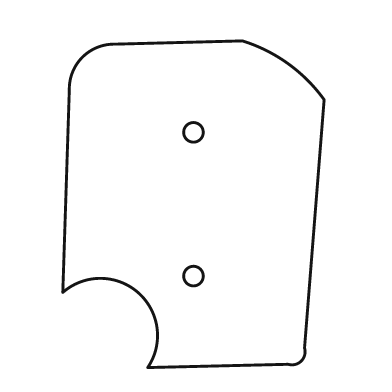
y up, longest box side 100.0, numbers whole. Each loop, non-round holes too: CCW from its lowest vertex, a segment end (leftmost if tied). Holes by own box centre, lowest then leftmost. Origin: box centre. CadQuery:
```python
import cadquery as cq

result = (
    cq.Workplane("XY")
    .moveTo(-14.0, -50.0)
    .lineTo(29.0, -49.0)
    .threePointArc((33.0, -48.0), (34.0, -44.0))
    .lineTo(40.0, 32.0)
    .threePointArc((29.0, 43.0), (15.0, 50.0))
    .lineTo(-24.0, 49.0)
    .threePointArc((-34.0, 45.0), (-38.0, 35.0))
    .lineTo(-40.0, -27.0)
    .threePointArc((-17.0, -27.0), (-14.0, -50.0))
    .close()
    .moveTo(0.0, -22.0)
    .circle(3.0)
    .moveTo(0.0, 22.0)
    .circle(3.0)
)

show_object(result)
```